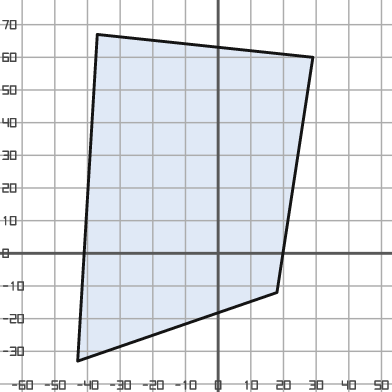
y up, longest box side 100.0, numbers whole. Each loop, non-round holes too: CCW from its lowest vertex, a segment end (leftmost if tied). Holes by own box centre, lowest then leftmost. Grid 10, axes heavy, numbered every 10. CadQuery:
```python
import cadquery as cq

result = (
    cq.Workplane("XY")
    .moveTo(-43.0, -33.0)
    .lineTo(18.0, -12.0)
    .lineTo(29.0, 60.0)
    .lineTo(-37.0, 67.0)
    .close()
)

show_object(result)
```